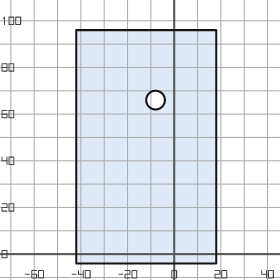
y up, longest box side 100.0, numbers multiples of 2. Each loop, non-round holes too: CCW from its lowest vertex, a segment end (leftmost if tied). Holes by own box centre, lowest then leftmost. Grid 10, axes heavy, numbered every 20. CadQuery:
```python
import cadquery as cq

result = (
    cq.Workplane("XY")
    .moveTo(-42.0, -4.0)
    .lineTo(18.0, -4.0)
    .lineTo(18.0, 96.0)
    .lineTo(-42.0, 96.0)
    .close()
    .moveTo(-8.0, 66.0)
    .circle(4.0)
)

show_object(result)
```